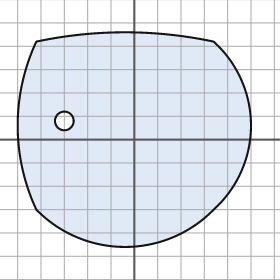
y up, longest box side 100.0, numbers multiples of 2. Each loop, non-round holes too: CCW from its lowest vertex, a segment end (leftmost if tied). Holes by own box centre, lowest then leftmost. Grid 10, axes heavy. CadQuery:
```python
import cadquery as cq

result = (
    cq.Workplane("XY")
    .moveTo(-42.0, -30.0)
    .threePointArc((-4.0, -46.0), (34.0, -30.0))
    .threePointArc((50.0, 6.0), (34.0, 42.0))
    .threePointArc((-4.0, 46.0), (-42.0, 42.0))
    .threePointArc((-50.0, 6.0), (-42.0, -30.0))
    .close()
    .moveTo(-30.0, 8.0)
    .circle(4.0)
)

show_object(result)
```